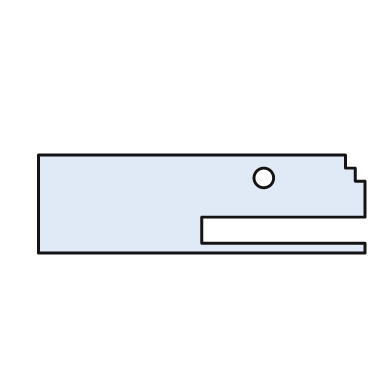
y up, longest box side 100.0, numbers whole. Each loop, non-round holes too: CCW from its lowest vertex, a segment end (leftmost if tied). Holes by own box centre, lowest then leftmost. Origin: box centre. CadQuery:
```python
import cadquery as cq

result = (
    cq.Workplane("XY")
    .moveTo(-50.0, -15.0)
    .lineTo(50.0, -15.0)
    .lineTo(50.0, -12.0)
    .lineTo(0.0, -12.0)
    .lineTo(0.0, -4.0)
    .lineTo(50.0, -4.0)
    .lineTo(50.0, 7.0)
    .lineTo(47.0, 7.0)
    .lineTo(47.0, 11.0)
    .lineTo(44.0, 11.0)
    .lineTo(44.0, 15.0)
    .lineTo(-50.0, 15.0)
    .close()
    .moveTo(19.0, 8.0)
    .circle(3.0)
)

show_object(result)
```